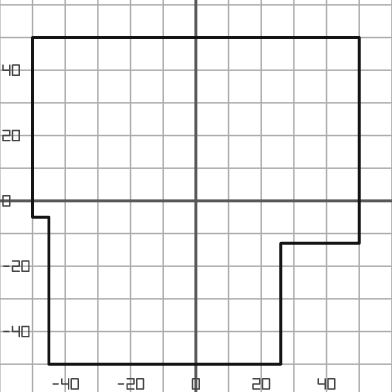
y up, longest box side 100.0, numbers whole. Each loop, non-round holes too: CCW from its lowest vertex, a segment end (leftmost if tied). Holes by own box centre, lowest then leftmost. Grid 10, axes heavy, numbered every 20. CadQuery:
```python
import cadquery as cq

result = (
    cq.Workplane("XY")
    .moveTo(-45.0, -50.0)
    .lineTo(26.0, -50.0)
    .lineTo(26.0, -13.0)
    .lineTo(50.0, -13.0)
    .lineTo(50.0, 50.0)
    .lineTo(-50.0, 50.0)
    .lineTo(-50.0, -5.0)
    .lineTo(-45.0, -5.0)
    .close()
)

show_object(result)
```